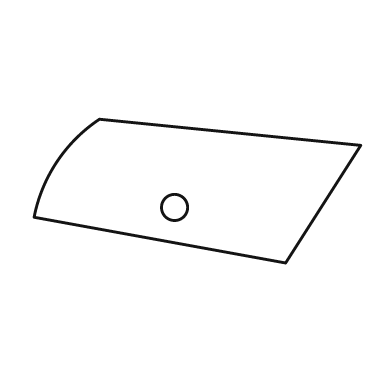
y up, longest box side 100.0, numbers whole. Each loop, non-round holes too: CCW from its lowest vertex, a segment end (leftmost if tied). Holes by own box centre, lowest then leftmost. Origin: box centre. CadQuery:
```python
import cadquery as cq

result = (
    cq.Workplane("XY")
    .moveTo(27.0, -22.0)
    .lineTo(50.0, 14.0)
    .lineTo(-30.0, 22.0)
    .threePointArc((-43.0, 9.0), (-50.0, -8.0))
    .close()
    .moveTo(-7.0, -5.0)
    .circle(4.0)
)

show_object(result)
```